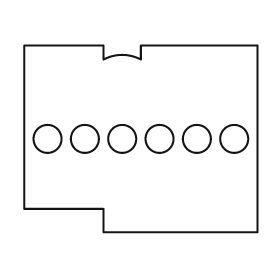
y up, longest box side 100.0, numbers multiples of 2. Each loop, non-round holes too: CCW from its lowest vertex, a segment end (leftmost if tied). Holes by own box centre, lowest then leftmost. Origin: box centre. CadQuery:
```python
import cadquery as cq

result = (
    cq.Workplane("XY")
    .moveTo(-16.0, -40.0)
    .lineTo(50.0, -40.0)
    .lineTo(50.0, 40.0)
    .lineTo(0.0, 40.0)
    .lineTo(0.0, 34.0)
    .threePointArc((-8.0, 36.0), (-16.0, 34.0))
    .lineTo(-16.0, 40.0)
    .lineTo(-50.0, 40.0)
    .lineTo(-50.0, -30.0)
    .lineTo(-16.0, -30.0)
    .close()
    .moveTo(-40.0, 0.0)
    .circle(6.0)
    .moveTo(-24.0, 0.0)
    .circle(6.0)
    .moveTo(-8.0, 0.0)
    .circle(6.0)
    .moveTo(8.0, 0.0)
    .circle(6.0)
    .moveTo(24.0, 0.0)
    .circle(6.0)
    .moveTo(40.0, 0.0)
    .circle(6.0)
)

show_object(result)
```